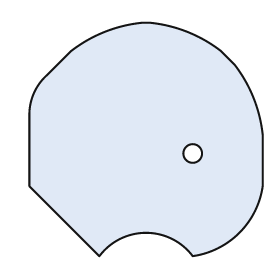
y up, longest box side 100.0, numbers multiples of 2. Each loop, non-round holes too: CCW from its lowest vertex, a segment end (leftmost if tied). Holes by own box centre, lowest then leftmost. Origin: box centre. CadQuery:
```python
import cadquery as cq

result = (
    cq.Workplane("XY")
    .moveTo(-20.0, -50.0)
    .threePointArc((0.0, -40.0), (20.0, -50.0))
    .threePointArc((40.0, -40.0), (50.0, -20.0))
    .lineTo(50.0, 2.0)
    .threePointArc((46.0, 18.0), (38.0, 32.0))
    .lineTo(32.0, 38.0)
    .threePointArc((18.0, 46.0), (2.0, 50.0))
    .lineTo(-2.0, 50.0)
    .threePointArc((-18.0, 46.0), (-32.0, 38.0))
    .lineTo(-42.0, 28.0)
    .threePointArc((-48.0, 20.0), (-50.0, 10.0))
    .lineTo(-50.0, -20.0)
    .close()
    .moveTo(20.0, -6.0)
    .circle(4.0)
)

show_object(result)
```